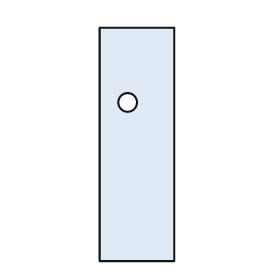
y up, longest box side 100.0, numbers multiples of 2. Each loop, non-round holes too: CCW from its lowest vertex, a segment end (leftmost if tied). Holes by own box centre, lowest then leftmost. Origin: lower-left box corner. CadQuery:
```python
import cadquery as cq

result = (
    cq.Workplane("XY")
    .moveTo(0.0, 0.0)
    .lineTo(32.0, 0.0)
    .lineTo(32.0, 100.0)
    .lineTo(0.0, 100.0)
    .close()
    .moveTo(12.0, 68.0)
    .circle(4.0)
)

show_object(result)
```